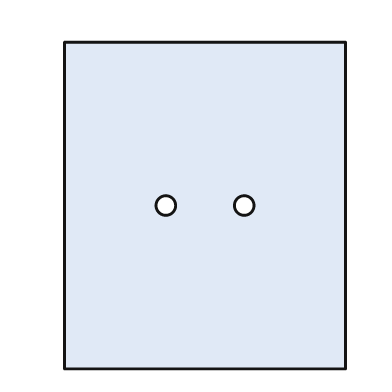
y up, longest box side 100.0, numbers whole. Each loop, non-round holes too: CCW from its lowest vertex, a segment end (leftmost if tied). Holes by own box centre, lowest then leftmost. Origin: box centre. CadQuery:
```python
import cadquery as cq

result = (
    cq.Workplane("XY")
    .moveTo(-43.0, -50.0)
    .lineTo(43.0, -50.0)
    .lineTo(43.0, 50.0)
    .lineTo(-43.0, 50.0)
    .close()
    .moveTo(-12.0, 0.0)
    .circle(3.0)
    .moveTo(12.0, 0.0)
    .circle(3.0)
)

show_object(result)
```